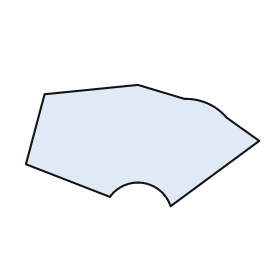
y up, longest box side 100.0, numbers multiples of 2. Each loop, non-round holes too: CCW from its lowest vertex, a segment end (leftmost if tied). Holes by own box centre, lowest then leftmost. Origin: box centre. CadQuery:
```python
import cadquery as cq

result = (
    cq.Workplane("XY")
    .moveTo(12.0, -26.0)
    .lineTo(50.0, 2.0)
    .lineTo(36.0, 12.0)
    .threePointArc((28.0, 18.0), (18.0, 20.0))
    .lineTo(-2.0, 26.0)
    .lineTo(-42.0, 22.0)
    .lineTo(-50.0, -8.0)
    .lineTo(-14.0, -22.0)
    .threePointArc((0.0, -16.0), (12.0, -26.0))
    .close()
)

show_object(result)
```